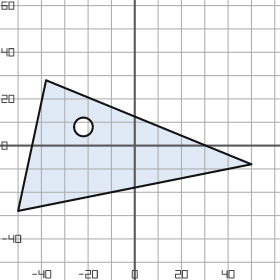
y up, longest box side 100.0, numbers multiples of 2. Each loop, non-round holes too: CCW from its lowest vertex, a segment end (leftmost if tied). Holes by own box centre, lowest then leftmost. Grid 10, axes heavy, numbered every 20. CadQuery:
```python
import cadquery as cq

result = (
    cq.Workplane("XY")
    .moveTo(-50.0, -28.0)
    .lineTo(50.0, -8.0)
    .lineTo(-38.0, 28.0)
    .close()
    .moveTo(-22.0, 8.0)
    .circle(4.0)
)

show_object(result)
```